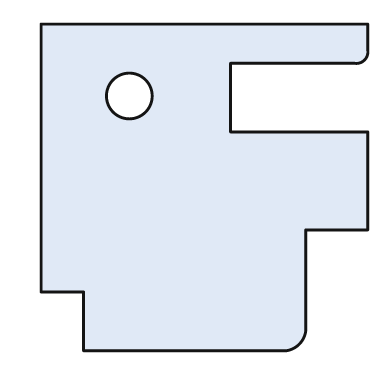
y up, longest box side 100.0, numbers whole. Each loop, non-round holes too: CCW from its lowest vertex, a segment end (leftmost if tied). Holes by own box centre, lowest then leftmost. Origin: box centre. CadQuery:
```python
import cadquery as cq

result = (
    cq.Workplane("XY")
    .moveTo(-37.0, -50.0)
    .lineTo(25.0, -50.0)
    .threePointArc((29.0, -48.0), (31.0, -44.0))
    .lineTo(31.0, -13.0)
    .lineTo(50.0, -13.0)
    .lineTo(50.0, 17.0)
    .lineTo(8.0, 17.0)
    .lineTo(8.0, 38.0)
    .lineTo(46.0, 38.0)
    .threePointArc((49.0, 39.0), (50.0, 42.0))
    .lineTo(50.0, 50.0)
    .lineTo(-50.0, 50.0)
    .lineTo(-50.0, -32.0)
    .lineTo(-37.0, -32.0)
    .close()
    .moveTo(-23.0, 28.0)
    .circle(7.0)
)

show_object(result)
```